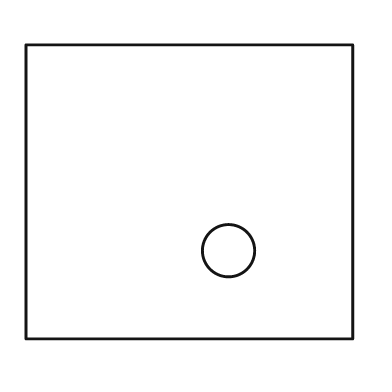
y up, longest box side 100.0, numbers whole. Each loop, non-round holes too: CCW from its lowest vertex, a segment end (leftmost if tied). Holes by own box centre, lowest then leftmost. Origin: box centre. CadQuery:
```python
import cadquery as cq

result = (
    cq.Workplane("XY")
    .moveTo(-50.0, -45.0)
    .lineTo(50.0, -45.0)
    .lineTo(50.0, 45.0)
    .lineTo(-50.0, 45.0)
    .close()
    .moveTo(12.0, -18.0)
    .circle(8.0)
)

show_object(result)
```